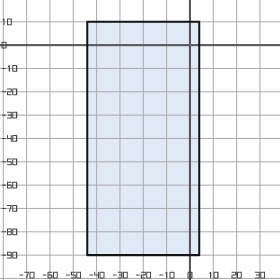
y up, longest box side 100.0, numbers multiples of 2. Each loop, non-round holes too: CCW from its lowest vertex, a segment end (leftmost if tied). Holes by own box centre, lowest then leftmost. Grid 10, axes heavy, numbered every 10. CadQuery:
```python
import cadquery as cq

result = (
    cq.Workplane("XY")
    .moveTo(-44.0, -90.0)
    .lineTo(4.0, -90.0)
    .lineTo(4.0, 10.0)
    .lineTo(-44.0, 10.0)
    .close()
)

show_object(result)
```